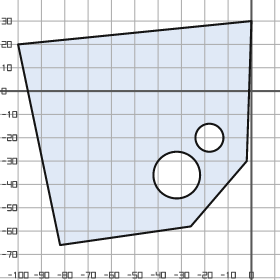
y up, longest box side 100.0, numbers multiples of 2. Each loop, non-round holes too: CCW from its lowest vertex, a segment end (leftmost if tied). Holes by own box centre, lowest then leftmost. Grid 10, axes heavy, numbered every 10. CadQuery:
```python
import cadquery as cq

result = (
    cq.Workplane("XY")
    .moveTo(-82.0, -66.0)
    .lineTo(-26.0, -58.0)
    .lineTo(-2.0, -30.0)
    .lineTo(0.0, 30.0)
    .lineTo(-100.0, 20.0)
    .close()
    .moveTo(-32.0, -36.0)
    .circle(10.0)
    .moveTo(-18.0, -20.0)
    .circle(6.0)
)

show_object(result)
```